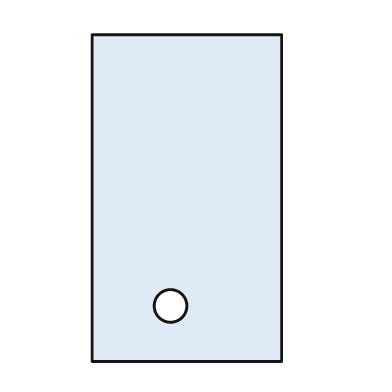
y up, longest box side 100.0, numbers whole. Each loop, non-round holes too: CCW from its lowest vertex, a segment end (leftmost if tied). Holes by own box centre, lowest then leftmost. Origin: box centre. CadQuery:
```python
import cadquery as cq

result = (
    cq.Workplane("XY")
    .moveTo(-29.0, -50.0)
    .lineTo(29.0, -50.0)
    .lineTo(29.0, 50.0)
    .lineTo(-29.0, 50.0)
    .close()
    .moveTo(-5.0, -33.0)
    .circle(5.0)
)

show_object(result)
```